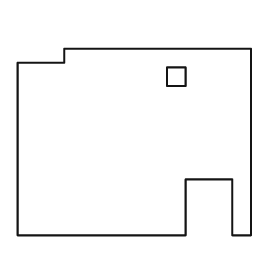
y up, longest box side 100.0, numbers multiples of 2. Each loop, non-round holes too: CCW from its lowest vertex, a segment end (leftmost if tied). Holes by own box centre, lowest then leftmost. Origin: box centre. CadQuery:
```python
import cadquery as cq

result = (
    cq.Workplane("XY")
    .moveTo(-50.0, -40.0)
    .lineTo(22.0, -40.0)
    .lineTo(22.0, -16.0)
    .lineTo(42.0, -16.0)
    .lineTo(42.0, -40.0)
    .lineTo(50.0, -40.0)
    .lineTo(50.0, 40.0)
    .lineTo(-30.0, 40.0)
    .lineTo(-30.0, 34.0)
    .lineTo(-50.0, 34.0)
    .close()
    .moveTo(14.0, 24.0)
    .lineTo(22.0, 24.0)
    .lineTo(22.0, 32.0)
    .lineTo(14.0, 32.0)
    .close()
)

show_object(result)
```